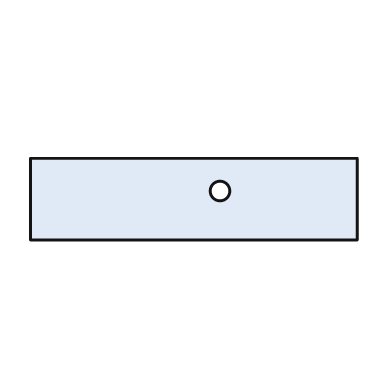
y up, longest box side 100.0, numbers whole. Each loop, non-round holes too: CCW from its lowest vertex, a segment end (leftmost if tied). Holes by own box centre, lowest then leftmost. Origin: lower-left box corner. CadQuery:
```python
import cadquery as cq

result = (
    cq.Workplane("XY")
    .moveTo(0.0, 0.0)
    .lineTo(100.0, 0.0)
    .lineTo(100.0, 25.0)
    .lineTo(0.0, 25.0)
    .close()
    .moveTo(58.0, 15.0)
    .circle(3.0)
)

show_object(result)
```